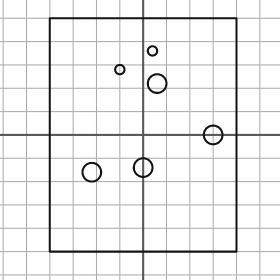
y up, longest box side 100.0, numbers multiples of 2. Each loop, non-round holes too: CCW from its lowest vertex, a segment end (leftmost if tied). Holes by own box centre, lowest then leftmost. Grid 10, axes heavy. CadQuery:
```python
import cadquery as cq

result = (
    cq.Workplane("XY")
    .moveTo(-40.0, -50.0)
    .lineTo(40.0, -50.0)
    .lineTo(40.0, 50.0)
    .lineTo(-40.0, 50.0)
    .close()
    .moveTo(-22.0, -16.0)
    .circle(4.0)
    .moveTo(0.0, -14.0)
    .circle(4.0)
    .moveTo(30.0, 0.0)
    .circle(4.0)
    .moveTo(6.0, 22.0)
    .circle(4.0)
    .moveTo(-10.0, 28.0)
    .circle(2.0)
    .moveTo(4.0, 36.0)
    .circle(2.0)
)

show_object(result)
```